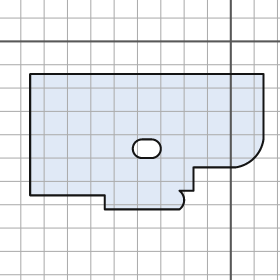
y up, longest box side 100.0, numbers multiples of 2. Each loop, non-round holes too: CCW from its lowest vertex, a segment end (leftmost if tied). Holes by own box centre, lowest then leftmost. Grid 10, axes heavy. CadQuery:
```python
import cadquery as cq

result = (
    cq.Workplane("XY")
    .moveTo(-54.0, -72.0)
    .lineTo(-22.0, -72.0)
    .threePointArc((-20.0, -68.0), (-22.0, -64.0))
    .lineTo(-16.0, -64.0)
    .lineTo(-16.0, -54.0)
    .lineTo(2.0, -54.0)
    .threePointArc((10.0, -50.0), (14.0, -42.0))
    .lineTo(14.0, -14.0)
    .lineTo(-86.0, -14.0)
    .lineTo(-86.0, -66.0)
    .lineTo(-54.0, -66.0)
    .close()
    .moveTo(-38.0, -50.0)
    .lineTo(-34.0, -50.0)
    .threePointArc((-30.0, -46.0), (-34.0, -42.0))
    .lineTo(-38.0, -42.0)
    .threePointArc((-42.0, -46.0), (-38.0, -50.0))
    .close()
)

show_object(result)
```